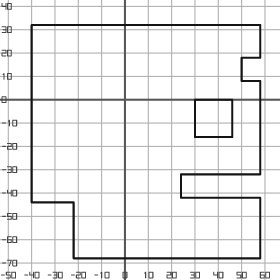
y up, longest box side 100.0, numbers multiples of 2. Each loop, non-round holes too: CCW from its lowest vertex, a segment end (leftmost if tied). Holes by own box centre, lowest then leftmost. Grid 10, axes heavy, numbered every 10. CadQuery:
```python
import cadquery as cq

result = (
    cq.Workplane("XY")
    .moveTo(-22.0, -68.0)
    .lineTo(58.0, -68.0)
    .lineTo(58.0, -42.0)
    .lineTo(24.0, -42.0)
    .lineTo(24.0, -32.0)
    .lineTo(58.0, -32.0)
    .lineTo(58.0, 8.0)
    .lineTo(50.0, 8.0)
    .lineTo(50.0, 18.0)
    .lineTo(58.0, 18.0)
    .lineTo(58.0, 32.0)
    .lineTo(-40.0, 32.0)
    .lineTo(-40.0, -44.0)
    .lineTo(-22.0, -44.0)
    .close()
    .moveTo(30.0, -16.0)
    .lineTo(46.0, -16.0)
    .lineTo(46.0, 0.0)
    .lineTo(30.0, 0.0)
    .close()
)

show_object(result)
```